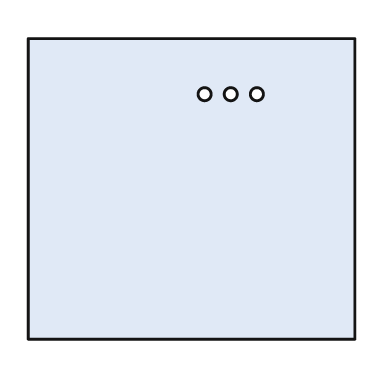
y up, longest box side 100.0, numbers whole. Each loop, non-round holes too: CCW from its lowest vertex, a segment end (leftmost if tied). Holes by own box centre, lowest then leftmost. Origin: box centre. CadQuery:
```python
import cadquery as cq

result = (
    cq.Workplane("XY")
    .moveTo(-50.0, -46.0)
    .lineTo(50.0, -46.0)
    .lineTo(50.0, 46.0)
    .lineTo(-50.0, 46.0)
    .close()
    .moveTo(4.0, 29.0)
    .circle(2.0)
    .moveTo(12.0, 29.0)
    .circle(2.0)
    .moveTo(20.0, 29.0)
    .circle(2.0)
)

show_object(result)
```